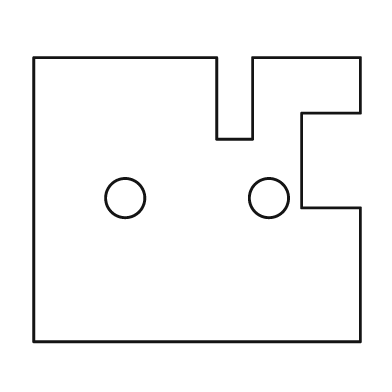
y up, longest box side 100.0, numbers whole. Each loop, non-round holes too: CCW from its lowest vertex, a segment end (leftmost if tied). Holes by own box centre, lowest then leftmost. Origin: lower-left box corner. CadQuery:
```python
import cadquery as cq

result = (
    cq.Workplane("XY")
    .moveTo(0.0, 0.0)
    .lineTo(100.0, 0.0)
    .lineTo(100.0, 41.0)
    .lineTo(82.0, 41.0)
    .lineTo(82.0, 70.0)
    .lineTo(100.0, 70.0)
    .lineTo(100.0, 87.0)
    .lineTo(67.0, 87.0)
    .lineTo(67.0, 62.0)
    .lineTo(56.0, 62.0)
    .lineTo(56.0, 87.0)
    .lineTo(0.0, 87.0)
    .close()
    .moveTo(28.0, 44.0)
    .circle(6.0)
    .moveTo(72.0, 44.0)
    .circle(6.0)
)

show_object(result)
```